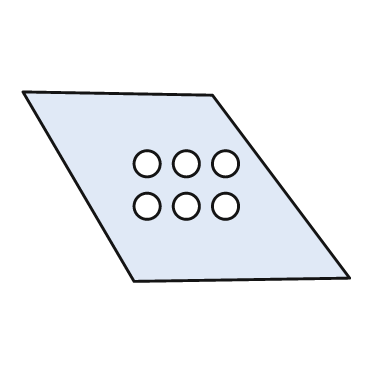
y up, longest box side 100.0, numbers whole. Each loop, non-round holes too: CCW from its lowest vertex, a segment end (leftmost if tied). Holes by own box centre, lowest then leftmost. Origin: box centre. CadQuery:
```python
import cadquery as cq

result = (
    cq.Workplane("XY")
    .moveTo(-16.0, -29.0)
    .lineTo(50.0, -28.0)
    .lineTo(8.0, 28.0)
    .lineTo(-50.0, 29.0)
    .close()
    .moveTo(-12.0, -6.0)
    .circle(4.0)
    .moveTo(0.0, -6.0)
    .circle(4.0)
    .moveTo(12.0, -6.0)
    .circle(4.0)
    .moveTo(-12.0, 7.0)
    .circle(4.0)
    .moveTo(0.0, 7.0)
    .circle(4.0)
    .moveTo(12.0, 7.0)
    .circle(4.0)
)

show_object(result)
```